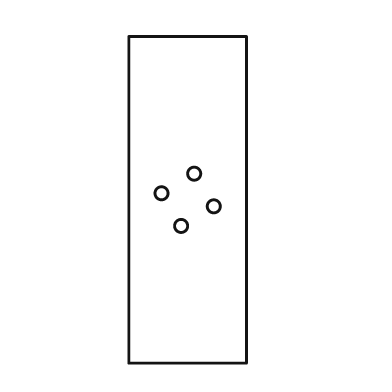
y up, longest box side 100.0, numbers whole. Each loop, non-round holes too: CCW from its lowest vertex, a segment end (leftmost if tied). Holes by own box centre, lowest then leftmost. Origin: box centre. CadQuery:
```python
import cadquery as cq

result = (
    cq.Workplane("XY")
    .moveTo(-18.0, -50.0)
    .lineTo(18.0, -50.0)
    .lineTo(18.0, 50.0)
    .lineTo(-18.0, 50.0)
    .close()
    .moveTo(-2.0, -8.0)
    .circle(2.0)
    .moveTo(8.0, -2.0)
    .circle(2.0)
    .moveTo(-8.0, 2.0)
    .circle(2.0)
    .moveTo(2.0, 8.0)
    .circle(2.0)
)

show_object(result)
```